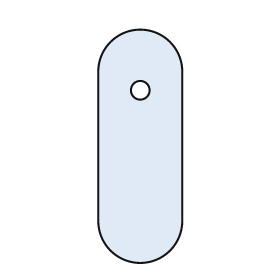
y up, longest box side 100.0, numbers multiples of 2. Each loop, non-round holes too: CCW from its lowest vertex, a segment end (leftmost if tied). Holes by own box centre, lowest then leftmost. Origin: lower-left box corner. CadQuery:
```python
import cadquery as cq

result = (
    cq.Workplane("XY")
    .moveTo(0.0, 18.0)
    .threePointArc((18.0, 0.0), (36.0, 18.0))
    .lineTo(36.0, 82.0)
    .threePointArc((18.0, 100.0), (0.0, 82.0))
    .close()
    .moveTo(18.0, 74.0)
    .circle(4.0)
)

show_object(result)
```